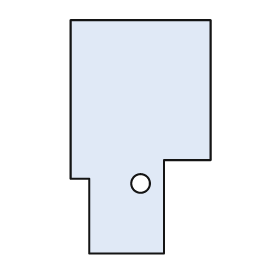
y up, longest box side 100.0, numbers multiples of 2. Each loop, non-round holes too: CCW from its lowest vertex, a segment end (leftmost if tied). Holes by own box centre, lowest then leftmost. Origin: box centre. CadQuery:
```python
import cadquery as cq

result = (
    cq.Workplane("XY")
    .moveTo(-22.0, -50.0)
    .lineTo(10.0, -50.0)
    .lineTo(10.0, -10.0)
    .lineTo(30.0, -10.0)
    .lineTo(30.0, 50.0)
    .lineTo(-30.0, 50.0)
    .lineTo(-30.0, -18.0)
    .lineTo(-22.0, -18.0)
    .close()
    .moveTo(0.0, -20.0)
    .circle(4.0)
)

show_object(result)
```